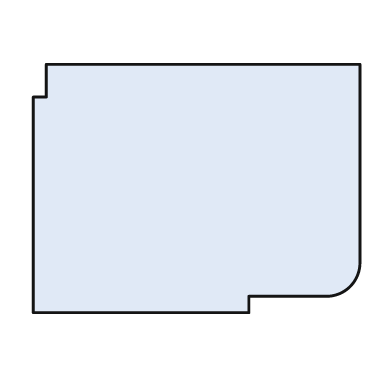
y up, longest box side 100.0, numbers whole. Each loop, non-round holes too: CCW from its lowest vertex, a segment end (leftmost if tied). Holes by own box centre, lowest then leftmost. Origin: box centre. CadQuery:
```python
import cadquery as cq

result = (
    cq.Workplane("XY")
    .moveTo(-50.0, -38.0)
    .lineTo(16.0, -38.0)
    .lineTo(16.0, -33.0)
    .lineTo(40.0, -33.0)
    .threePointArc((47.0, -30.0), (50.0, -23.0))
    .lineTo(50.0, 38.0)
    .lineTo(-46.0, 38.0)
    .lineTo(-46.0, 28.0)
    .lineTo(-50.0, 28.0)
    .close()
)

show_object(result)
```